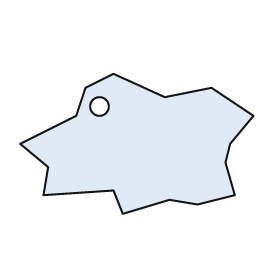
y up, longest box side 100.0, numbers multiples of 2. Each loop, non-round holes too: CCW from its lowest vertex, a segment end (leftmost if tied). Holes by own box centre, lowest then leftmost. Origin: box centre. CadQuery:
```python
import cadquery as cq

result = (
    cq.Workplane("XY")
    .moveTo(-6.0, -30.0)
    .lineTo(14.0, -24.0)
    .lineTo(26.0, -26.0)
    .lineTo(42.0, -22.0)
    .lineTo(38.0, -8.0)
    .lineTo(40.0, 0.0)
    .lineTo(50.0, 12.0)
    .lineTo(32.0, 24.0)
    .lineTo(12.0, 20.0)
    .lineTo(-10.0, 30.0)
    .lineTo(-22.0, 24.0)
    .lineTo(-26.0, 12.0)
    .lineTo(-50.0, 0.0)
    .lineTo(-38.0, -10.0)
    .lineTo(-40.0, -22.0)
    .lineTo(-10.0, -20.0)
    .close()
    .moveTo(-16.0, 16.0)
    .circle(4.0)
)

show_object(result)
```